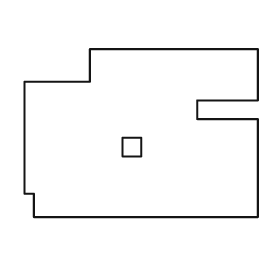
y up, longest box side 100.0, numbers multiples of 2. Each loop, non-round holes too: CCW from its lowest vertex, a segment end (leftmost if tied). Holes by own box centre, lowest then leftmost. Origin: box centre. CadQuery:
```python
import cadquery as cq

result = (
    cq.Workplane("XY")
    .moveTo(-46.0, -36.0)
    .lineTo(50.0, -36.0)
    .lineTo(50.0, 6.0)
    .lineTo(24.0, 6.0)
    .lineTo(24.0, 14.0)
    .lineTo(50.0, 14.0)
    .lineTo(50.0, 36.0)
    .lineTo(-22.0, 36.0)
    .lineTo(-22.0, 22.0)
    .lineTo(-50.0, 22.0)
    .lineTo(-50.0, -26.0)
    .lineTo(-46.0, -26.0)
    .close()
    .moveTo(-8.0, -10.0)
    .lineTo(0.0, -10.0)
    .lineTo(0.0, -2.0)
    .lineTo(-8.0, -2.0)
    .close()
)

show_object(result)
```